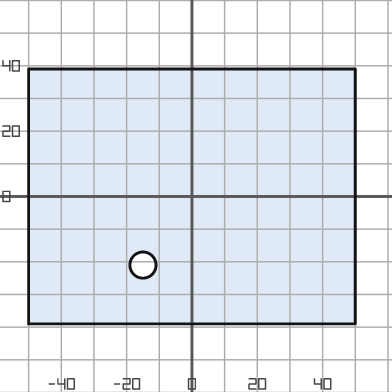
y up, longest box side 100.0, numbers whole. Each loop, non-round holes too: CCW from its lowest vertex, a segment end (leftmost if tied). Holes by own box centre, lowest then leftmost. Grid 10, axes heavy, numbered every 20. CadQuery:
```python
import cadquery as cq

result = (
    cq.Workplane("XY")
    .moveTo(-50.0, -39.0)
    .lineTo(50.0, -39.0)
    .lineTo(50.0, 39.0)
    .lineTo(-50.0, 39.0)
    .close()
    .moveTo(-15.0, -21.0)
    .circle(4.0)
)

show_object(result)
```